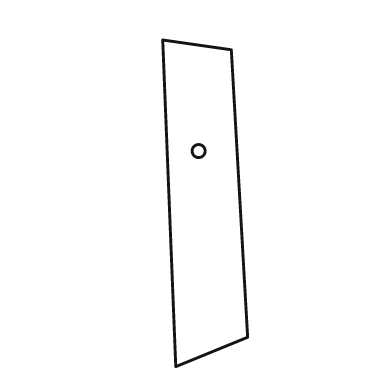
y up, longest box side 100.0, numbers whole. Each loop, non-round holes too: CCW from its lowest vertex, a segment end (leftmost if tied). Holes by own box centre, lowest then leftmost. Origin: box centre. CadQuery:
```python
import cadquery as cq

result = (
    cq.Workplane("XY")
    .moveTo(-9.0, -50.0)
    .lineTo(13.0, -41.0)
    .lineTo(8.0, 47.0)
    .lineTo(-13.0, 50.0)
    .close()
    .moveTo(-2.0, 16.0)
    .circle(2.0)
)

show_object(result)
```